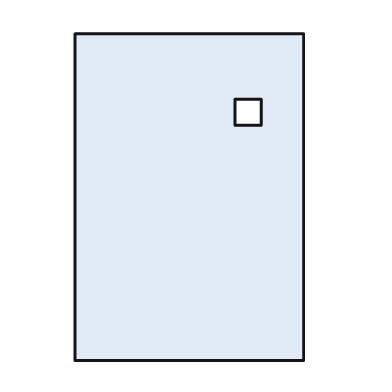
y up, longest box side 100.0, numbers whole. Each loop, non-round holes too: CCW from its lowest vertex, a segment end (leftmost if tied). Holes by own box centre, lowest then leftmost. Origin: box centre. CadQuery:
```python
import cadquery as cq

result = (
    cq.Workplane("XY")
    .moveTo(-35.0, -50.0)
    .lineTo(35.0, -50.0)
    .lineTo(35.0, 50.0)
    .lineTo(-35.0, 50.0)
    .close()
    .moveTo(14.0, 22.0)
    .lineTo(22.0, 22.0)
    .lineTo(22.0, 30.0)
    .lineTo(14.0, 30.0)
    .close()
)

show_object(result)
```